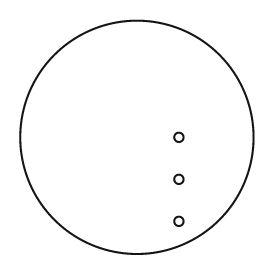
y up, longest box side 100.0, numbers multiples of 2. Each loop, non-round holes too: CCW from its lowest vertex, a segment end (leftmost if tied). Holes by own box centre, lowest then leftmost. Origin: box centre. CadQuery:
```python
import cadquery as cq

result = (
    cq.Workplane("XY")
    .moveTo(0.0, 0.0)
    .circle(50.0)
    .moveTo(18.0, -36.0)
    .circle(2.0)
    .moveTo(18.0, -18.0)
    .circle(2.0)
    .moveTo(18.0, 0.0)
    .circle(2.0)
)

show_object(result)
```